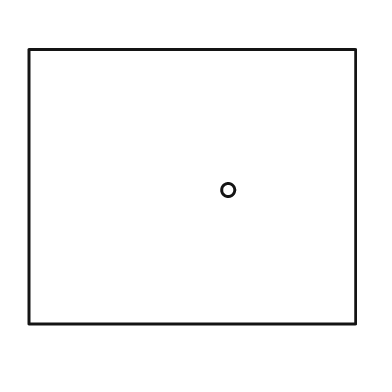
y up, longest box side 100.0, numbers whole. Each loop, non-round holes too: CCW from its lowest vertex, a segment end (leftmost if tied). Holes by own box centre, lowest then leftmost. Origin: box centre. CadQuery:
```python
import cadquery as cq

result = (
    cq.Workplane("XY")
    .moveTo(-50.0, -42.0)
    .lineTo(50.0, -42.0)
    .lineTo(50.0, 42.0)
    .lineTo(-50.0, 42.0)
    .close()
    .moveTo(11.0, -1.0)
    .circle(2.0)
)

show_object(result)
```